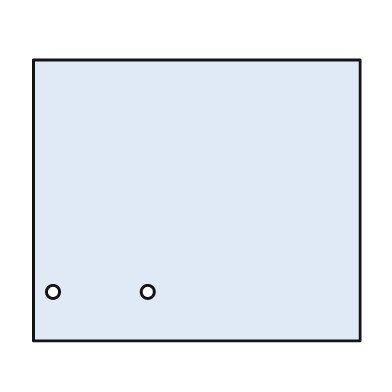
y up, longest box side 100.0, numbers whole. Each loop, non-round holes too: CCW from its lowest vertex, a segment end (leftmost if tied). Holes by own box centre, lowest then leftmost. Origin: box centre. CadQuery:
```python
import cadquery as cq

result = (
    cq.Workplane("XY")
    .moveTo(-50.0, -43.0)
    .lineTo(50.0, -43.0)
    .lineTo(50.0, 43.0)
    .lineTo(-50.0, 43.0)
    .close()
    .moveTo(-44.0, -28.0)
    .circle(2.0)
    .moveTo(-15.0, -28.0)
    .circle(2.0)
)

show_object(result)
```